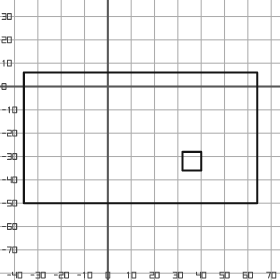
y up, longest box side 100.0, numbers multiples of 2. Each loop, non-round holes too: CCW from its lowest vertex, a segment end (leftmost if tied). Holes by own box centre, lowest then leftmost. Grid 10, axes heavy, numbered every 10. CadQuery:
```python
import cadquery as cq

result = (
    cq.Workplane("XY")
    .moveTo(-36.0, -50.0)
    .lineTo(64.0, -50.0)
    .lineTo(64.0, 6.0)
    .lineTo(-36.0, 6.0)
    .close()
    .moveTo(32.0, -36.0)
    .lineTo(40.0, -36.0)
    .lineTo(40.0, -28.0)
    .lineTo(32.0, -28.0)
    .close()
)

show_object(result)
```